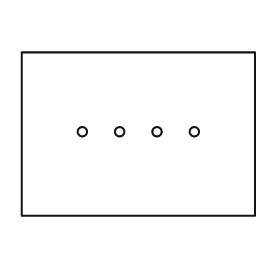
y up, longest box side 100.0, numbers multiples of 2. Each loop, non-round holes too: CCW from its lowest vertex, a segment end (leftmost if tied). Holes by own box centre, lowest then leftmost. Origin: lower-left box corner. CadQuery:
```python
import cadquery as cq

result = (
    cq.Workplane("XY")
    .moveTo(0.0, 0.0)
    .lineTo(100.0, 0.0)
    .lineTo(100.0, 70.0)
    .lineTo(0.0, 70.0)
    .close()
    .moveTo(26.0, 36.0)
    .circle(2.0)
    .moveTo(42.0, 36.0)
    .circle(2.0)
    .moveTo(58.0, 36.0)
    .circle(2.0)
    .moveTo(74.0, 36.0)
    .circle(2.0)
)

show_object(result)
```